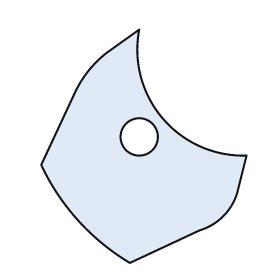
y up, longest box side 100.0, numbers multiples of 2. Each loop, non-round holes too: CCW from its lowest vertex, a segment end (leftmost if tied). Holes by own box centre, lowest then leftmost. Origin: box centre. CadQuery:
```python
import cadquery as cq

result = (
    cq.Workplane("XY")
    .moveTo(-6.0, -50.0)
    .lineTo(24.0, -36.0)
    .threePointArc((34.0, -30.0), (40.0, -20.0))
    .lineTo(44.0, -4.0)
    .threePointArc((8.0, 12.0), (-2.0, 50.0))
    .lineTo(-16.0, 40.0)
    .threePointArc((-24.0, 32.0), (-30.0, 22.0))
    .lineTo(-44.0, -8.0)
    .threePointArc((-28.0, -32.0), (-6.0, -50.0))
    .close()
    .moveTo(-2.0, 4.0)
    .circle(8.0)
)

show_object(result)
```